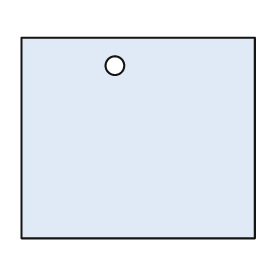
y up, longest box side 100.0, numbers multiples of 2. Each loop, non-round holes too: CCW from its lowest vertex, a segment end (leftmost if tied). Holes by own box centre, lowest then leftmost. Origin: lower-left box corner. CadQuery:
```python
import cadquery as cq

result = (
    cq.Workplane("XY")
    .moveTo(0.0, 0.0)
    .lineTo(100.0, 0.0)
    .lineTo(100.0, 86.0)
    .lineTo(0.0, 86.0)
    .close()
    .moveTo(40.0, 74.0)
    .circle(4.0)
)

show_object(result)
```